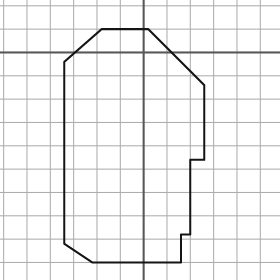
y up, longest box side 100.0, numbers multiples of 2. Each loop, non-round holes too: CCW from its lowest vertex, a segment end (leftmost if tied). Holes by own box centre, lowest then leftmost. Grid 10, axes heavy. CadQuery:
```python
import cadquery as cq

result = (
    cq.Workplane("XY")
    .moveTo(-22.0, -90.0)
    .lineTo(16.0, -90.0)
    .lineTo(16.0, -78.0)
    .lineTo(20.0, -78.0)
    .lineTo(20.0, -46.0)
    .lineTo(26.0, -46.0)
    .lineTo(26.0, -14.0)
    .lineTo(2.0, 10.0)
    .lineTo(-18.0, 10.0)
    .lineTo(-34.0, -4.0)
    .lineTo(-34.0, -82.0)
    .close()
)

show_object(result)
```